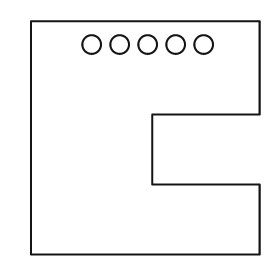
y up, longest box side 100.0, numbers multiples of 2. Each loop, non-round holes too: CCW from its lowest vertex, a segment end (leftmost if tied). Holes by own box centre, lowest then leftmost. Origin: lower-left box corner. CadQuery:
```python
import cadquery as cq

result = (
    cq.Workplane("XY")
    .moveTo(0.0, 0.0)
    .lineTo(98.0, 0.0)
    .lineTo(98.0, 30.0)
    .lineTo(52.0, 30.0)
    .lineTo(52.0, 60.0)
    .lineTo(98.0, 60.0)
    .lineTo(98.0, 100.0)
    .lineTo(0.0, 100.0)
    .close()
    .moveTo(26.0, 90.0)
    .circle(4.0)
    .moveTo(38.0, 90.0)
    .circle(4.0)
    .moveTo(50.0, 90.0)
    .circle(4.0)
    .moveTo(62.0, 90.0)
    .circle(4.0)
    .moveTo(74.0, 90.0)
    .circle(4.0)
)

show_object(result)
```